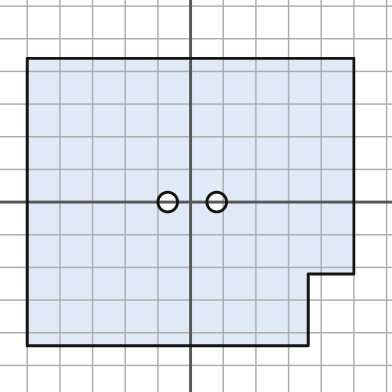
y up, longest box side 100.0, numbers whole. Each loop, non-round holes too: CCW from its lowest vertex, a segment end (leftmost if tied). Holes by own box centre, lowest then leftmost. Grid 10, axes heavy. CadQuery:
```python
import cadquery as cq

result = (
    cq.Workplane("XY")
    .moveTo(-50.0, -44.0)
    .lineTo(36.0, -44.0)
    .lineTo(36.0, -22.0)
    .lineTo(50.0, -22.0)
    .lineTo(50.0, 44.0)
    .lineTo(-50.0, 44.0)
    .close()
    .moveTo(-7.0, 0.0)
    .circle(3.0)
    .moveTo(8.0, 0.0)
    .circle(3.0)
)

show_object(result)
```